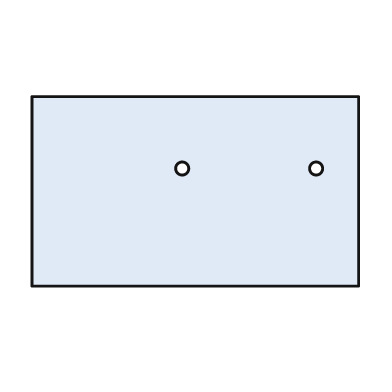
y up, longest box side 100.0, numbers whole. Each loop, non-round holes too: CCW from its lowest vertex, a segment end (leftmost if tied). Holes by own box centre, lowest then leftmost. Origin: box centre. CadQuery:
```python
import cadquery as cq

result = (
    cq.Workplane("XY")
    .moveTo(-50.0, -29.0)
    .lineTo(50.0, -29.0)
    .lineTo(50.0, 29.0)
    .lineTo(-50.0, 29.0)
    .close()
    .moveTo(-4.0, 7.0)
    .circle(2.0)
    .moveTo(37.0, 7.0)
    .circle(2.0)
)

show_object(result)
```